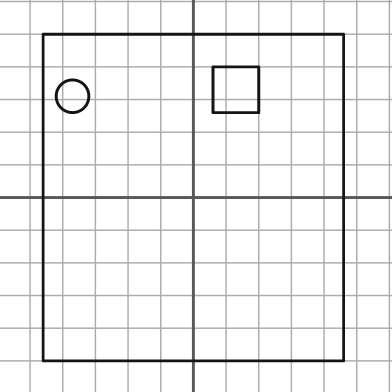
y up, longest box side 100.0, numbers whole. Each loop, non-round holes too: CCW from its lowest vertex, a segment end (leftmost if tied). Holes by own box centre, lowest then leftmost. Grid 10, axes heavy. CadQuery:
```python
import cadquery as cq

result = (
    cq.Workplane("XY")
    .moveTo(-46.0, -50.0)
    .lineTo(46.0, -50.0)
    .lineTo(46.0, 50.0)
    .lineTo(-46.0, 50.0)
    .close()
    .moveTo(-37.0, 31.0)
    .circle(5.0)
    .moveTo(6.0, 26.0)
    .lineTo(20.0, 26.0)
    .lineTo(20.0, 40.0)
    .lineTo(6.0, 40.0)
    .close()
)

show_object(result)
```